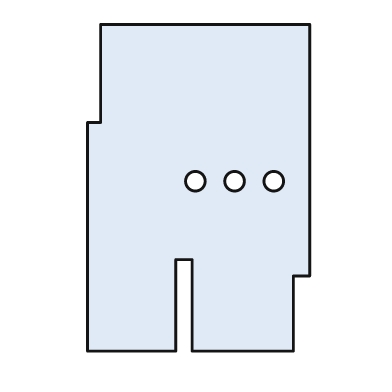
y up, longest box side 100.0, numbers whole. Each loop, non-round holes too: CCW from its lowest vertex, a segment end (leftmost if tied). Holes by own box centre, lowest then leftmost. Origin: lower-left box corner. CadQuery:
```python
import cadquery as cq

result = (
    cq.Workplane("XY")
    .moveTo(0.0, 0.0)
    .lineTo(27.0, 0.0)
    .lineTo(27.0, 28.0)
    .lineTo(32.0, 28.0)
    .lineTo(32.0, 0.0)
    .lineTo(63.0, 0.0)
    .lineTo(63.0, 23.0)
    .lineTo(68.0, 23.0)
    .lineTo(68.0, 100.0)
    .lineTo(4.0, 100.0)
    .lineTo(4.0, 70.0)
    .lineTo(0.0, 70.0)
    .close()
    .moveTo(33.0, 52.0)
    .circle(3.0)
    .moveTo(45.0, 52.0)
    .circle(3.0)
    .moveTo(57.0, 52.0)
    .circle(3.0)
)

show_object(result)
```